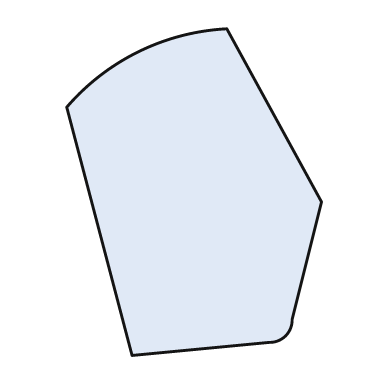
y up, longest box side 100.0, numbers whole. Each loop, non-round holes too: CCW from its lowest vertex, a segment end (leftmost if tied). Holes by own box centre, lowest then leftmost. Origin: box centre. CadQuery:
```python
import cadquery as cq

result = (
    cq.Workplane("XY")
    .moveTo(-19.0, -50.0)
    .lineTo(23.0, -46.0)
    .threePointArc((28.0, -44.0), (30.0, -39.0))
    .lineTo(39.0, -3.0)
    .lineTo(10.0, 50.0)
    .threePointArc((-17.0, 43.0), (-39.0, 26.0))
    .close()
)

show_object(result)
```